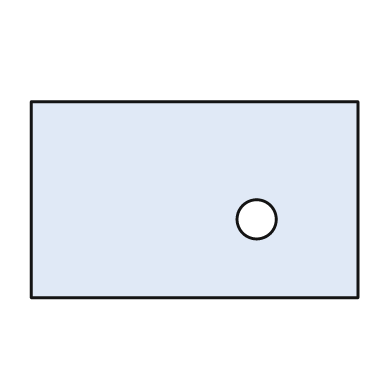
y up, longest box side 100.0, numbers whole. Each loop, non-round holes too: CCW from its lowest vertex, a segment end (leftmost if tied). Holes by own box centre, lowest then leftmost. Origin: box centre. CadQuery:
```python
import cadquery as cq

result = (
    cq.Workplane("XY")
    .moveTo(-50.0, -30.0)
    .lineTo(50.0, -30.0)
    .lineTo(50.0, 30.0)
    .lineTo(-50.0, 30.0)
    .close()
    .moveTo(19.0, -6.0)
    .circle(6.0)
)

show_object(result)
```